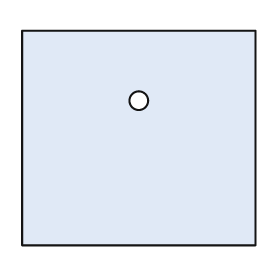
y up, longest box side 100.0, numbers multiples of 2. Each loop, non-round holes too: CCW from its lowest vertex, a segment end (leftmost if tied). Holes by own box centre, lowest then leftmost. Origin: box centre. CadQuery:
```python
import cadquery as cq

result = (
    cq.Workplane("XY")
    .moveTo(-50.0, -46.0)
    .lineTo(50.0, -46.0)
    .lineTo(50.0, 46.0)
    .lineTo(-50.0, 46.0)
    .close()
    .moveTo(0.0, 16.0)
    .circle(4.0)
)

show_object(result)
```